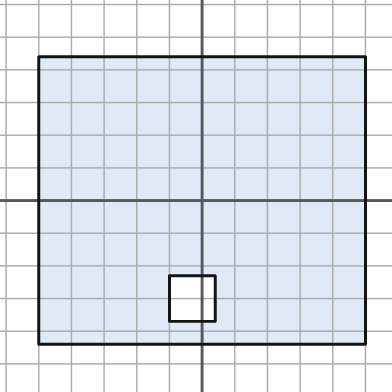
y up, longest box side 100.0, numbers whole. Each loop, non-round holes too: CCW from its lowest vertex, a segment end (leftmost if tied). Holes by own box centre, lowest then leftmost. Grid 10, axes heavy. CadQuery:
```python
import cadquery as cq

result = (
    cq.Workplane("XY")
    .moveTo(-50.0, -44.0)
    .lineTo(50.0, -44.0)
    .lineTo(50.0, 44.0)
    .lineTo(-50.0, 44.0)
    .close()
    .moveTo(-10.0, -37.0)
    .lineTo(4.0, -37.0)
    .lineTo(4.0, -23.0)
    .lineTo(-10.0, -23.0)
    .close()
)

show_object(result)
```